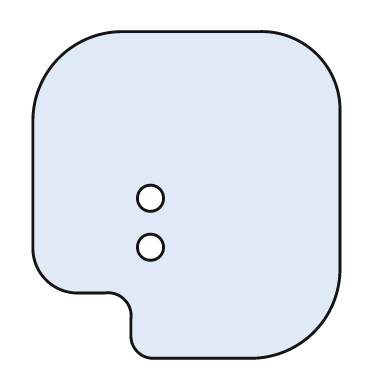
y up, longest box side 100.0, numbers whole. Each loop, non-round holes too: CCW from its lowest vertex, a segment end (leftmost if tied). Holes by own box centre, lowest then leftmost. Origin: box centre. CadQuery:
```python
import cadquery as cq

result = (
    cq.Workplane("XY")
    .moveTo(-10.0, -50.0)
    .lineTo(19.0, -50.0)
    .threePointArc((39.0, -42.0), (47.0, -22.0))
    .lineTo(47.0, 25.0)
    .threePointArc((40.0, 43.0), (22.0, 50.0))
    .lineTo(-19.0, 50.0)
    .threePointArc((-39.0, 42.0), (-47.0, 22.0))
    .lineTo(-47.0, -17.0)
    .threePointArc((-43.0, -26.0), (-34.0, -30.0))
    .lineTo(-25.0, -30.0)
    .threePointArc((-19.0, -32.0), (-17.0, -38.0))
    .lineTo(-17.0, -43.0)
    .threePointArc((-15.0, -48.0), (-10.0, -50.0))
    .close()
    .moveTo(-11.0, -16.0)
    .circle(4.0)
    .moveTo(-11.0, -1.0)
    .circle(4.0)
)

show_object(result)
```